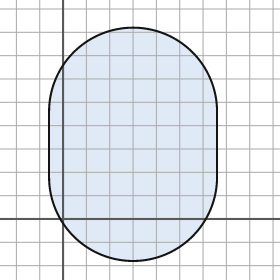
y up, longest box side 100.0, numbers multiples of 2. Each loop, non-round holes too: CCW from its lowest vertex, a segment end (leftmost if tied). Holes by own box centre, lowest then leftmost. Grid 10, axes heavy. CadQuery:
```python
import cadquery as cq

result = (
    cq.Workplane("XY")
    .moveTo(-6.0, 18.0)
    .threePointArc((30.0, -18.0), (66.0, 18.0))
    .lineTo(66.0, 46.0)
    .threePointArc((30.0, 82.0), (-6.0, 46.0))
    .close()
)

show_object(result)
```